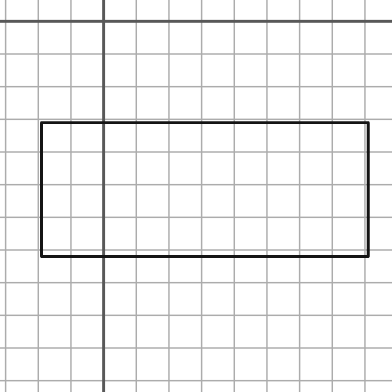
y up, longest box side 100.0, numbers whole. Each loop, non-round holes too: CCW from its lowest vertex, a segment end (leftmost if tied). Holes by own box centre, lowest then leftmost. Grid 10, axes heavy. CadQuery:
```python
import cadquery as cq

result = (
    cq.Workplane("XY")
    .moveTo(-19.0, -72.0)
    .lineTo(81.0, -72.0)
    .lineTo(81.0, -31.0)
    .lineTo(-19.0, -31.0)
    .close()
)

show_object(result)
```